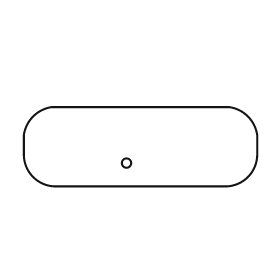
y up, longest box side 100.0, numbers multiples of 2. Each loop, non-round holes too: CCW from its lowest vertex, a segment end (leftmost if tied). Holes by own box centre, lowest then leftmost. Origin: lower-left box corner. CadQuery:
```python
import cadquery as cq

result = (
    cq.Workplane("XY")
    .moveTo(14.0, 0.0)
    .lineTo(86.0, 0.0)
    .threePointArc((96.0, 4.0), (100.0, 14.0))
    .lineTo(100.0, 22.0)
    .threePointArc((96.0, 30.0), (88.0, 34.0))
    .lineTo(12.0, 34.0)
    .threePointArc((4.0, 30.0), (0.0, 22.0))
    .lineTo(0.0, 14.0)
    .threePointArc((4.0, 4.0), (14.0, 0.0))
    .close()
    .moveTo(44.0, 10.0)
    .circle(2.0)
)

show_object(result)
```